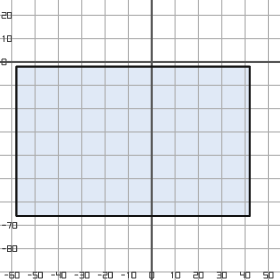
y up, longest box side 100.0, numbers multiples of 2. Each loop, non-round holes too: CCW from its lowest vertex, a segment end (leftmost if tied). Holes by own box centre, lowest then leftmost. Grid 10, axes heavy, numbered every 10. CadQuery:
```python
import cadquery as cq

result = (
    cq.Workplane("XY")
    .moveTo(-58.0, -66.0)
    .lineTo(42.0, -66.0)
    .lineTo(42.0, -2.0)
    .lineTo(-58.0, -2.0)
    .close()
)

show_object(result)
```